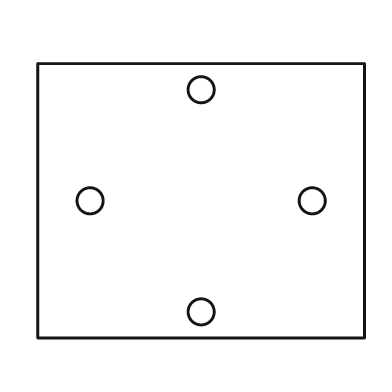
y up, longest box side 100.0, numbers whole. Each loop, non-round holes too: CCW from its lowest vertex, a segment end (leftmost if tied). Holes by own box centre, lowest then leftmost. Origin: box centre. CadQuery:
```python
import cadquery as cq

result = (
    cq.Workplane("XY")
    .moveTo(-50.0, -42.0)
    .lineTo(50.0, -42.0)
    .lineTo(50.0, 42.0)
    .lineTo(-50.0, 42.0)
    .close()
    .moveTo(0.0, -34.0)
    .circle(4.0)
    .moveTo(-34.0, 0.0)
    .circle(4.0)
    .moveTo(34.0, 0.0)
    .circle(4.0)
    .moveTo(0.0, 34.0)
    .circle(4.0)
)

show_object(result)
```